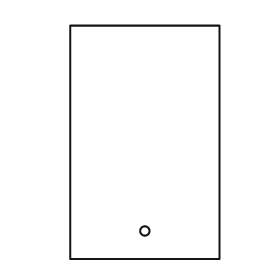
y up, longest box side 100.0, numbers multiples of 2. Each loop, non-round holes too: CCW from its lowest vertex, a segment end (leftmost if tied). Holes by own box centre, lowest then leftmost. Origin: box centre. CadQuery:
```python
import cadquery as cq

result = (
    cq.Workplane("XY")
    .moveTo(-32.0, -50.0)
    .lineTo(32.0, -50.0)
    .lineTo(32.0, 50.0)
    .lineTo(-32.0, 50.0)
    .close()
    .moveTo(0.0, -38.0)
    .circle(2.0)
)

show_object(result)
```